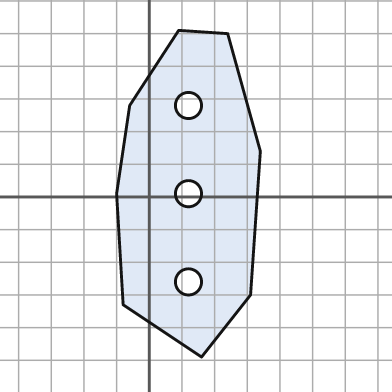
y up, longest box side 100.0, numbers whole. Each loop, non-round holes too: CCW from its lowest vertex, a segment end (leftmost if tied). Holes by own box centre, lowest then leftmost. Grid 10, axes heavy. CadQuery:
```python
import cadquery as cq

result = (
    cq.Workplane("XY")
    .moveTo(16.0, -49.0)
    .lineTo(31.0, -30.0)
    .lineTo(34.0, 14.0)
    .lineTo(24.0, 50.0)
    .lineTo(9.0, 51.0)
    .lineTo(-6.0, 28.0)
    .lineTo(-10.0, 1.0)
    .lineTo(-8.0, -33.0)
    .close()
    .moveTo(12.0, -26.0)
    .circle(4.0)
    .moveTo(12.0, 1.0)
    .circle(4.0)
    .moveTo(12.0, 28.0)
    .circle(4.0)
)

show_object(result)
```